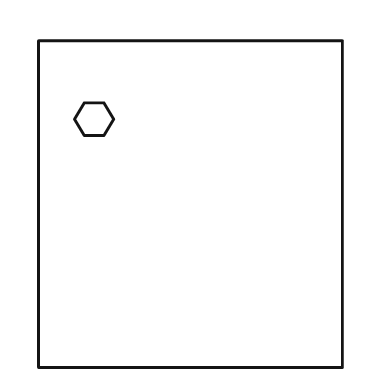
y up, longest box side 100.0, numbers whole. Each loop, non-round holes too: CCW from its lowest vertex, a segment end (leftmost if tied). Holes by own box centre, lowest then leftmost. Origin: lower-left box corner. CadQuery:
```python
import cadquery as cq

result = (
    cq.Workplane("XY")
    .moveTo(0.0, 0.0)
    .lineTo(93.0, 0.0)
    .lineTo(93.0, 100.0)
    .lineTo(0.0, 100.0)
    .close()
    .moveTo(14.0, 71.0)
    .lineTo(20.0, 71.0)
    .lineTo(23.0, 76.0)
    .lineTo(20.0, 81.0)
    .lineTo(14.0, 81.0)
    .lineTo(11.0, 76.0)
    .close()
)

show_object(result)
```